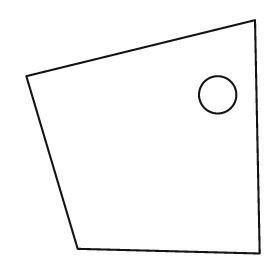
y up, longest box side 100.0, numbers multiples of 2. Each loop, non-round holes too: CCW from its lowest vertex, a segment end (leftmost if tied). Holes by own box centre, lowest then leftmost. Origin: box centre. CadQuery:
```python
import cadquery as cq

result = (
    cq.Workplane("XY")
    .moveTo(50.0, -50.0)
    .lineTo(48.0, 50.0)
    .lineTo(-50.0, 26.0)
    .lineTo(-28.0, -48.0)
    .close()
    .moveTo(32.0, 18.0)
    .circle(8.0)
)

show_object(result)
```